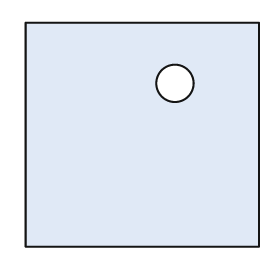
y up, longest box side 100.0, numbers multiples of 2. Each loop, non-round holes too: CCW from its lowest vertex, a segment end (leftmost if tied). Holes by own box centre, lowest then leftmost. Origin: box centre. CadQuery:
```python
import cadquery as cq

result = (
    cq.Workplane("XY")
    .moveTo(-50.0, -48.0)
    .lineTo(50.0, -48.0)
    .lineTo(50.0, 48.0)
    .lineTo(-50.0, 48.0)
    .close()
    .moveTo(14.0, 22.0)
    .circle(8.0)
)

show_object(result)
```